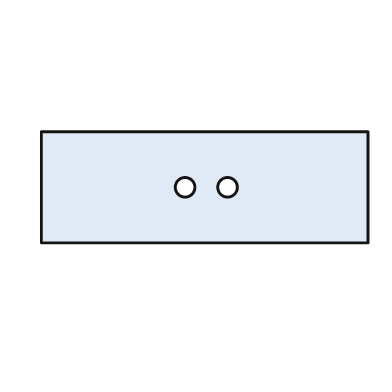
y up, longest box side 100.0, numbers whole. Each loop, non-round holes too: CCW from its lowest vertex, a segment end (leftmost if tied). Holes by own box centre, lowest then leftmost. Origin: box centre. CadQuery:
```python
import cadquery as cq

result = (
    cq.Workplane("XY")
    .moveTo(-50.0, -17.0)
    .lineTo(50.0, -17.0)
    .lineTo(50.0, 17.0)
    .lineTo(-50.0, 17.0)
    .close()
    .moveTo(-6.0, 0.0)
    .circle(3.0)
    .moveTo(7.0, 0.0)
    .circle(3.0)
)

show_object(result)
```